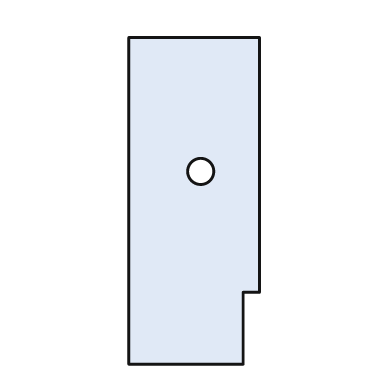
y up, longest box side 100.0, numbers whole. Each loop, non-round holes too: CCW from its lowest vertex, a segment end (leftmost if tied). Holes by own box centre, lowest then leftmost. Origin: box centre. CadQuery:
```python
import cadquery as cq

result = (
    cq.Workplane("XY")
    .moveTo(-20.0, -50.0)
    .lineTo(15.0, -50.0)
    .lineTo(15.0, -28.0)
    .lineTo(20.0, -28.0)
    .lineTo(20.0, 50.0)
    .lineTo(-20.0, 50.0)
    .close()
    .moveTo(2.0, 9.0)
    .circle(4.0)
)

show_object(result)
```